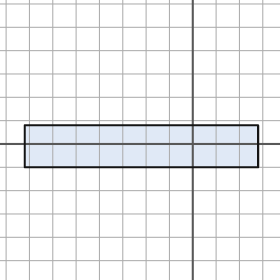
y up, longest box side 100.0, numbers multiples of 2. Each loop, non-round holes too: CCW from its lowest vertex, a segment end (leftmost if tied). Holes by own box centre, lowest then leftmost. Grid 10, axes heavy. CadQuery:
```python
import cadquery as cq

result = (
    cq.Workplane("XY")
    .moveTo(-72.0, -10.0)
    .lineTo(28.0, -10.0)
    .lineTo(28.0, 8.0)
    .lineTo(-72.0, 8.0)
    .close()
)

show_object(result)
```